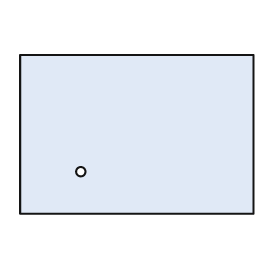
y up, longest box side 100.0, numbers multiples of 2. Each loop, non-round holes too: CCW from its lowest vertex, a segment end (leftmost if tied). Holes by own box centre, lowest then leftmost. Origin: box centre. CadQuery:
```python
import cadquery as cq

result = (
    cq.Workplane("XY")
    .moveTo(-50.0, -34.0)
    .lineTo(50.0, -34.0)
    .lineTo(50.0, 34.0)
    .lineTo(-50.0, 34.0)
    .close()
    .moveTo(-24.0, -16.0)
    .circle(2.0)
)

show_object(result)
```